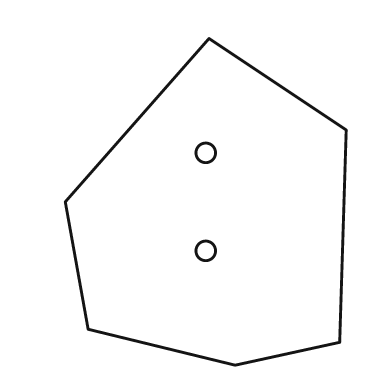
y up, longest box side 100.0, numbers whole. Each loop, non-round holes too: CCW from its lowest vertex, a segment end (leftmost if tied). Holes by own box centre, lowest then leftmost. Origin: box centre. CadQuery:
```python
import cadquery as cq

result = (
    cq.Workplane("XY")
    .moveTo(9.0, -50.0)
    .lineTo(41.0, -43.0)
    .lineTo(43.0, 22.0)
    .lineTo(1.0, 50.0)
    .lineTo(-43.0, 0.0)
    .lineTo(-36.0, -39.0)
    .close()
    .moveTo(0.0, -15.0)
    .circle(3.0)
    .moveTo(0.0, 15.0)
    .circle(3.0)
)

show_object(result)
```